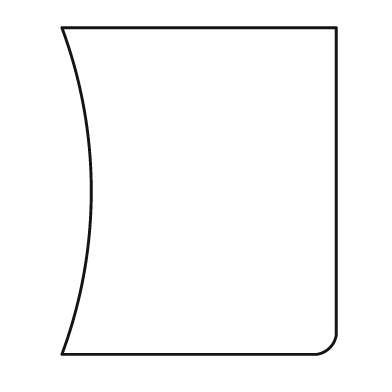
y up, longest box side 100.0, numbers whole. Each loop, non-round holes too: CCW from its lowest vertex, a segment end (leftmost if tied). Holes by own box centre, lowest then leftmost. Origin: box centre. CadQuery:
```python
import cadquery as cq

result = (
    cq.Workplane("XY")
    .moveTo(-42.0, -50.0)
    .lineTo(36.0, -50.0)
    .threePointArc((40.0, -48.0), (42.0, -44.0))
    .lineTo(42.0, 50.0)
    .lineTo(-42.0, 50.0)
    .threePointArc((-33.0, 0.0), (-42.0, -50.0))
    .close()
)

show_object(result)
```